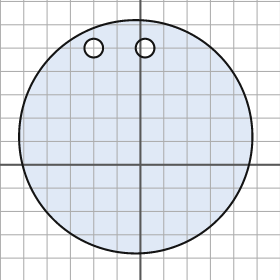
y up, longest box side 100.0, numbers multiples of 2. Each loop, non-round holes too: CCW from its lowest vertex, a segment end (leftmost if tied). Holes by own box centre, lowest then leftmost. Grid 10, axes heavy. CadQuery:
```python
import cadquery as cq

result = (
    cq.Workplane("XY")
    .moveTo(-2.0, 12.0)
    .circle(50.0)
    .moveTo(-20.0, 50.0)
    .circle(4.0)
    .moveTo(2.0, 50.0)
    .circle(4.0)
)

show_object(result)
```